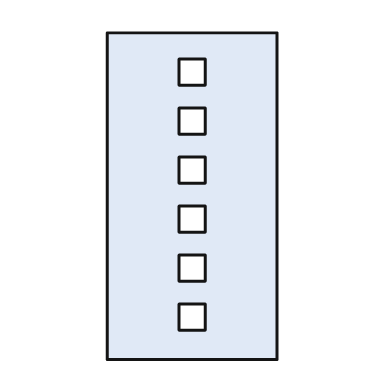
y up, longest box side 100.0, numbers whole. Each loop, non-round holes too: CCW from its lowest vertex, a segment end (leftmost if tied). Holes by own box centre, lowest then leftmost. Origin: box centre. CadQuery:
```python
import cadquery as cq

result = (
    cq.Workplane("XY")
    .moveTo(-26.0, -50.0)
    .lineTo(26.0, -50.0)
    .lineTo(26.0, 50.0)
    .lineTo(-26.0, 50.0)
    .close()
    .moveTo(-4.0, -41.0)
    .lineTo(4.0, -41.0)
    .lineTo(4.0, -33.0)
    .lineTo(-4.0, -33.0)
    .close()
    .moveTo(-4.0, -26.0)
    .lineTo(4.0, -26.0)
    .lineTo(4.0, -18.0)
    .lineTo(-4.0, -18.0)
    .close()
    .moveTo(-4.0, -11.0)
    .lineTo(4.0, -11.0)
    .lineTo(4.0, -3.0)
    .lineTo(-4.0, -3.0)
    .close()
    .moveTo(-4.0, 4.0)
    .lineTo(4.0, 4.0)
    .lineTo(4.0, 12.0)
    .lineTo(-4.0, 12.0)
    .close()
    .moveTo(-4.0, 19.0)
    .lineTo(4.0, 19.0)
    .lineTo(4.0, 27.0)
    .lineTo(-4.0, 27.0)
    .close()
    .moveTo(-4.0, 34.0)
    .lineTo(4.0, 34.0)
    .lineTo(4.0, 42.0)
    .lineTo(-4.0, 42.0)
    .close()
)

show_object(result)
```